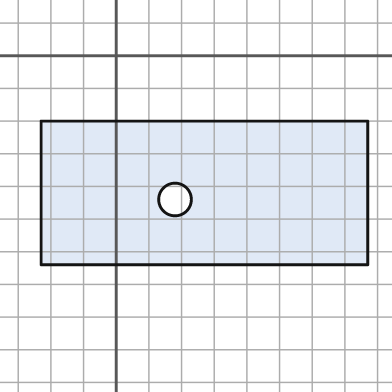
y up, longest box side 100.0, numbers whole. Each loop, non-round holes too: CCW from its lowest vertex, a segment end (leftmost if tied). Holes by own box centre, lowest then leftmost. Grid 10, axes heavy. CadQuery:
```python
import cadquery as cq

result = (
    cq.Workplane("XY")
    .moveTo(-23.0, -64.0)
    .lineTo(77.0, -64.0)
    .lineTo(77.0, -20.0)
    .lineTo(-23.0, -20.0)
    .close()
    .moveTo(18.0, -44.0)
    .circle(5.0)
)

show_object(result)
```